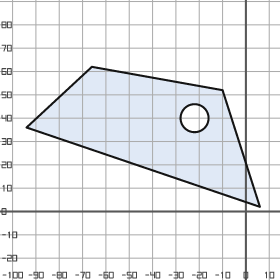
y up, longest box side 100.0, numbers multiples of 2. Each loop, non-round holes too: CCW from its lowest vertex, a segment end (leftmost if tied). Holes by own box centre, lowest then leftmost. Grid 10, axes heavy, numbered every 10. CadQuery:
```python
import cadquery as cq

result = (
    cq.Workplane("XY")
    .moveTo(6.0, 2.0)
    .lineTo(-10.0, 52.0)
    .lineTo(-66.0, 62.0)
    .lineTo(-94.0, 36.0)
    .close()
    .moveTo(-22.0, 40.0)
    .circle(6.0)
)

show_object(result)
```